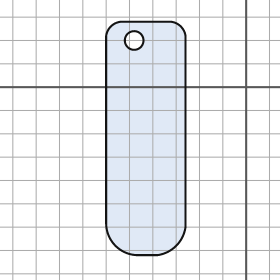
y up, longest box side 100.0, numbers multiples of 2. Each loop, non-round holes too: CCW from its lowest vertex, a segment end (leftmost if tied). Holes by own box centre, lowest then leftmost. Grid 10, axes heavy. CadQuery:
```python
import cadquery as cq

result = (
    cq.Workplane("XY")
    .moveTo(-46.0, -72.0)
    .lineTo(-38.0, -72.0)
    .threePointArc((-30.0, -68.0), (-26.0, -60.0))
    .lineTo(-26.0, 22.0)
    .threePointArc((-28.0, 26.0), (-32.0, 28.0))
    .lineTo(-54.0, 28.0)
    .threePointArc((-58.0, 26.0), (-60.0, 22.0))
    .lineTo(-60.0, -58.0)
    .threePointArc((-56.0, -68.0), (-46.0, -72.0))
    .close()
    .moveTo(-48.0, 20.0)
    .circle(4.0)
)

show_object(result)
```